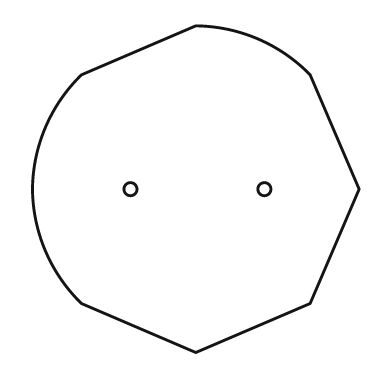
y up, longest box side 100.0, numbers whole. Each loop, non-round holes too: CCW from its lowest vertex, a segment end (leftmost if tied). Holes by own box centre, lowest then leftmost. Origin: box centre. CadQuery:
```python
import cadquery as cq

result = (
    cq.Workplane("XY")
    .moveTo(0.0, -50.0)
    .lineTo(35.0, -35.0)
    .lineTo(50.0, 0.0)
    .lineTo(35.0, 35.0)
    .threePointArc((19.0, 46.0), (0.0, 50.0))
    .lineTo(-35.0, 35.0)
    .threePointArc((-46.0, 19.0), (-50.0, 0.0))
    .threePointArc((-46.0, -19.0), (-35.0, -35.0))
    .close()
    .moveTo(-20.0, 0.0)
    .circle(2.0)
    .moveTo(21.0, 0.0)
    .circle(2.0)
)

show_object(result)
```